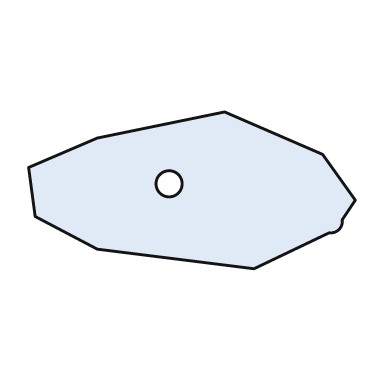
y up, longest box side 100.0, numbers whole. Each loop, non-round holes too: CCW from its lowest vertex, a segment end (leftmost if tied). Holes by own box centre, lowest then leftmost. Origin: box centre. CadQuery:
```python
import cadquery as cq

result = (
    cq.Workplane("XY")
    .moveTo(19.0, -24.0)
    .lineTo(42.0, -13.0)
    .threePointArc((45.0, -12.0), (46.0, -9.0))
    .lineTo(50.0, -3.0)
    .lineTo(40.0, 11.0)
    .lineTo(10.0, 24.0)
    .lineTo(-29.0, 16.0)
    .lineTo(-50.0, 7.0)
    .lineTo(-48.0, -8.0)
    .lineTo(-29.0, -18.0)
    .close()
    .moveTo(-7.0, 2.0)
    .circle(4.0)
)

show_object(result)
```